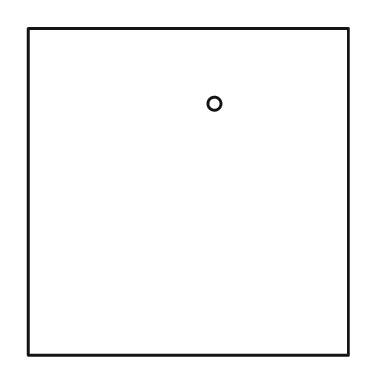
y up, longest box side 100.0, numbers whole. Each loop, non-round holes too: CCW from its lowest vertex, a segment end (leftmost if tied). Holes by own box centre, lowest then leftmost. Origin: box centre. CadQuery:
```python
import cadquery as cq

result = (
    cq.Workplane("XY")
    .moveTo(-49.0, -50.0)
    .lineTo(49.0, -50.0)
    .lineTo(49.0, 50.0)
    .lineTo(-49.0, 50.0)
    .close()
    .moveTo(8.0, 27.0)
    .circle(2.0)
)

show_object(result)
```